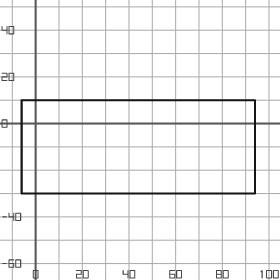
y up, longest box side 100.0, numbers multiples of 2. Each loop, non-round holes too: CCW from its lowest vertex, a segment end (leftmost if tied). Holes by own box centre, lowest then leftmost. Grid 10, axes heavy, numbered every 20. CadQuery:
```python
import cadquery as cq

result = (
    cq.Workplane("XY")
    .moveTo(-6.0, -30.0)
    .lineTo(94.0, -30.0)
    .lineTo(94.0, 10.0)
    .lineTo(-6.0, 10.0)
    .close()
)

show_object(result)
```